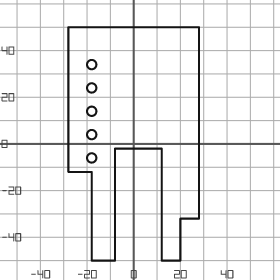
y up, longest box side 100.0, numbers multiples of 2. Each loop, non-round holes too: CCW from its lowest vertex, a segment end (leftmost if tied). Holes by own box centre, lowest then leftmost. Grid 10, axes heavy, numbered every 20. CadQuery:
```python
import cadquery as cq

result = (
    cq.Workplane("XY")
    .moveTo(-18.0, -50.0)
    .lineTo(-8.0, -50.0)
    .lineTo(-8.0, -2.0)
    .lineTo(12.0, -2.0)
    .lineTo(12.0, -50.0)
    .lineTo(20.0, -50.0)
    .lineTo(20.0, -32.0)
    .lineTo(28.0, -32.0)
    .lineTo(28.0, 50.0)
    .lineTo(-28.0, 50.0)
    .lineTo(-28.0, -12.0)
    .lineTo(-18.0, -12.0)
    .close()
    .moveTo(-18.0, -6.0)
    .circle(2.0)
    .moveTo(-18.0, 4.0)
    .circle(2.0)
    .moveTo(-18.0, 14.0)
    .circle(2.0)
    .moveTo(-18.0, 24.0)
    .circle(2.0)
    .moveTo(-18.0, 34.0)
    .circle(2.0)
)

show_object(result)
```